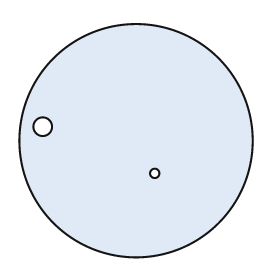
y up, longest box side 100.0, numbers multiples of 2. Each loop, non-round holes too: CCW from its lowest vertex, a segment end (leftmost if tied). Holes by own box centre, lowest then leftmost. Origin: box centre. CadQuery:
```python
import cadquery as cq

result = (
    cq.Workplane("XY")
    .moveTo(0.0, 0.0)
    .circle(50.0)
    .moveTo(8.0, -14.0)
    .circle(2.0)
    .moveTo(-40.0, 6.0)
    .circle(4.0)
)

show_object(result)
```